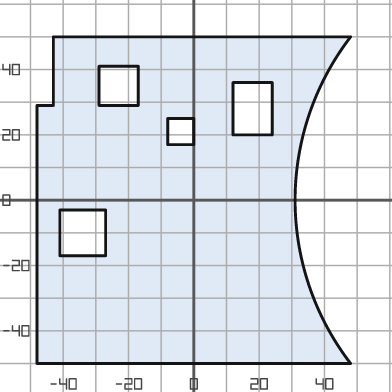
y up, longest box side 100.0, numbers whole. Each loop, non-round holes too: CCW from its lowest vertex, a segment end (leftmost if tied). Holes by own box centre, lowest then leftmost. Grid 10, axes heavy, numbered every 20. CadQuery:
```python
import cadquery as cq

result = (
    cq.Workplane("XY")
    .moveTo(-48.0, -50.0)
    .lineTo(48.0, -50.0)
    .threePointArc((31.0, 0.0), (48.0, 50.0))
    .lineTo(-43.0, 50.0)
    .lineTo(-43.0, 29.0)
    .lineTo(-48.0, 29.0)
    .close()
    .moveTo(-41.0, -17.0)
    .lineTo(-27.0, -17.0)
    .lineTo(-27.0, -3.0)
    .lineTo(-41.0, -3.0)
    .close()
    .moveTo(-8.0, 17.0)
    .lineTo(0.0, 17.0)
    .lineTo(0.0, 25.0)
    .lineTo(-8.0, 25.0)
    .close()
    .moveTo(12.0, 20.0)
    .lineTo(24.0, 20.0)
    .lineTo(24.0, 36.0)
    .lineTo(12.0, 36.0)
    .close()
    .moveTo(-29.0, 29.0)
    .lineTo(-17.0, 29.0)
    .lineTo(-17.0, 41.0)
    .lineTo(-29.0, 41.0)
    .close()
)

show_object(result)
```